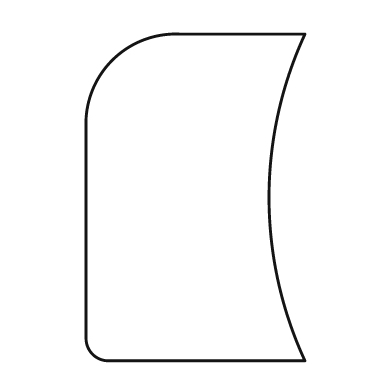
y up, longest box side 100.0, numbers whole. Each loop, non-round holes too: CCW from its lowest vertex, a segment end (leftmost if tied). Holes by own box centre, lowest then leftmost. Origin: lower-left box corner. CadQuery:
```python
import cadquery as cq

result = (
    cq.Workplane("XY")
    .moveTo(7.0, 0.0)
    .lineTo(67.0, 0.0)
    .threePointArc((56.0, 50.0), (67.0, 100.0))
    .lineTo(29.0, 100.0)
    .threePointArc((8.0, 92.0), (0.0, 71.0))
    .lineTo(0.0, 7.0)
    .threePointArc((2.0, 2.0), (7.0, 0.0))
    .close()
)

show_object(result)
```